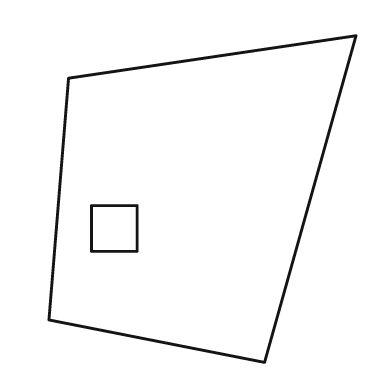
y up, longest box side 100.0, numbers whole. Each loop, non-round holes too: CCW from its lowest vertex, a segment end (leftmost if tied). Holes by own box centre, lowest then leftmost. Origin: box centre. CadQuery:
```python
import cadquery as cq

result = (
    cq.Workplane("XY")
    .moveTo(19.0, -50.0)
    .lineTo(47.0, 50.0)
    .lineTo(-41.0, 37.0)
    .lineTo(-47.0, -37.0)
    .close()
    .moveTo(-34.0, -16.0)
    .lineTo(-20.0, -16.0)
    .lineTo(-20.0, -2.0)
    .lineTo(-34.0, -2.0)
    .close()
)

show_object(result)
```